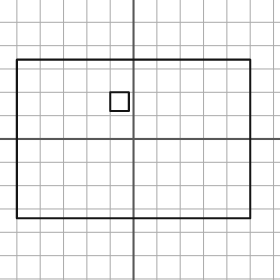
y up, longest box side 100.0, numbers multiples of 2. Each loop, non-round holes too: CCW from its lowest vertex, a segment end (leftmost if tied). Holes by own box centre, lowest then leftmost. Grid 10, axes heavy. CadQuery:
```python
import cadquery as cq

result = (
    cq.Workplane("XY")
    .moveTo(-50.0, -34.0)
    .lineTo(50.0, -34.0)
    .lineTo(50.0, 34.0)
    .lineTo(-50.0, 34.0)
    .close()
    .moveTo(-10.0, 12.0)
    .lineTo(-2.0, 12.0)
    .lineTo(-2.0, 20.0)
    .lineTo(-10.0, 20.0)
    .close()
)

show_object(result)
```